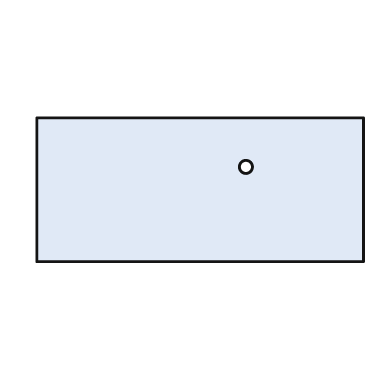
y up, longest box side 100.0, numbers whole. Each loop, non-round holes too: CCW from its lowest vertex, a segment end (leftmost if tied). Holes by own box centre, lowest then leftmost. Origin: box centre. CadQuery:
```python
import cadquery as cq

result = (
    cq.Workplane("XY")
    .moveTo(-50.0, -22.0)
    .lineTo(50.0, -22.0)
    .lineTo(50.0, 22.0)
    .lineTo(-50.0, 22.0)
    .close()
    .moveTo(14.0, 7.0)
    .circle(2.0)
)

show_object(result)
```